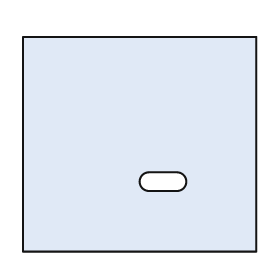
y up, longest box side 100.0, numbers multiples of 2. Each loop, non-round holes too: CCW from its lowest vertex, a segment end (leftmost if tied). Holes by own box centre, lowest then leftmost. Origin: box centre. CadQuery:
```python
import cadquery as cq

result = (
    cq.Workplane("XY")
    .moveTo(-50.0, -46.0)
    .lineTo(50.0, -46.0)
    .lineTo(50.0, 46.0)
    .lineTo(-50.0, 46.0)
    .close()
    .moveTo(4.0, -20.0)
    .lineTo(16.0, -20.0)
    .threePointArc((20.0, -16.0), (16.0, -12.0))
    .lineTo(4.0, -12.0)
    .threePointArc((0.0, -16.0), (4.0, -20.0))
    .close()
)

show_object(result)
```